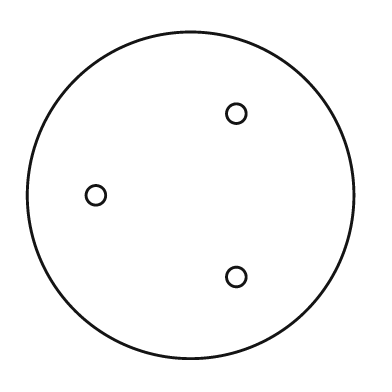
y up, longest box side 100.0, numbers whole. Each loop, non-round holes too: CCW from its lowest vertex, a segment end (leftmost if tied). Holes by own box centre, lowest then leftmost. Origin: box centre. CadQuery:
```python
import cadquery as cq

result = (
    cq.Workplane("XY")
    .moveTo(0.0, 0.0)
    .circle(50.0)
    .moveTo(14.0, -25.0)
    .circle(3.0)
    .moveTo(-29.0, 0.0)
    .circle(3.0)
    .moveTo(14.0, 25.0)
    .circle(3.0)
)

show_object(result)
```